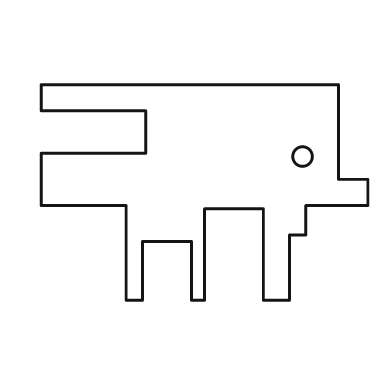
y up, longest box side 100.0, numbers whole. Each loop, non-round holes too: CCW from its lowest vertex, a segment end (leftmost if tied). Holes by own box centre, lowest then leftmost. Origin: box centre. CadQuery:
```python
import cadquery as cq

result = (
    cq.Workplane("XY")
    .moveTo(-24.0, -33.0)
    .lineTo(-19.0, -33.0)
    .lineTo(-19.0, -15.0)
    .lineTo(-4.0, -15.0)
    .lineTo(-4.0, -33.0)
    .lineTo(0.0, -33.0)
    .lineTo(0.0, -5.0)
    .lineTo(18.0, -5.0)
    .lineTo(18.0, -33.0)
    .lineTo(26.0, -33.0)
    .lineTo(26.0, -13.0)
    .lineTo(31.0, -13.0)
    .lineTo(31.0, -4.0)
    .lineTo(50.0, -4.0)
    .lineTo(50.0, 4.0)
    .lineTo(41.0, 4.0)
    .lineTo(41.0, 33.0)
    .lineTo(-50.0, 33.0)
    .lineTo(-50.0, 25.0)
    .lineTo(-18.0, 25.0)
    .lineTo(-18.0, 12.0)
    .lineTo(-50.0, 12.0)
    .lineTo(-50.0, -4.0)
    .lineTo(-24.0, -4.0)
    .close()
    .moveTo(30.0, 11.0)
    .circle(3.0)
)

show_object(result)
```